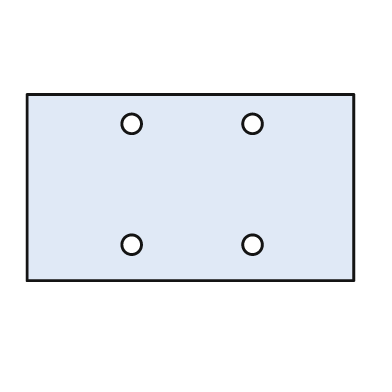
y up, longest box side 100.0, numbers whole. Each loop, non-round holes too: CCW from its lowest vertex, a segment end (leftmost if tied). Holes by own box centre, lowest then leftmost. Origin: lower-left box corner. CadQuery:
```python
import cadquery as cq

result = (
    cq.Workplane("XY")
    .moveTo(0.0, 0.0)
    .lineTo(100.0, 0.0)
    .lineTo(100.0, 57.0)
    .lineTo(0.0, 57.0)
    .close()
    .moveTo(32.0, 11.0)
    .circle(3.0)
    .moveTo(69.0, 11.0)
    .circle(3.0)
    .moveTo(32.0, 48.0)
    .circle(3.0)
    .moveTo(69.0, 48.0)
    .circle(3.0)
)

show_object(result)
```